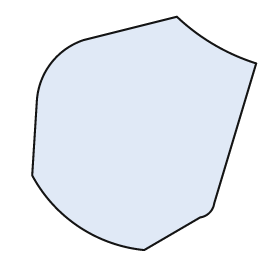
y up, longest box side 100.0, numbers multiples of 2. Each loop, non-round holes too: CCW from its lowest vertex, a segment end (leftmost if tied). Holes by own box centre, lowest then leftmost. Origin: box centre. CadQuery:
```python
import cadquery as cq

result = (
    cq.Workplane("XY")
    .moveTo(0.0, -50.0)
    .lineTo(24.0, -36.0)
    .threePointArc((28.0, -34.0), (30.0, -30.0))
    .lineTo(48.0, 30.0)
    .threePointArc((30.0, 38.0), (14.0, 50.0))
    .lineTo(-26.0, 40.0)
    .threePointArc((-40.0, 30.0), (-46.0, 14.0))
    .lineTo(-48.0, -18.0)
    .threePointArc((-28.0, -40.0), (0.0, -50.0))
    .close()
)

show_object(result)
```